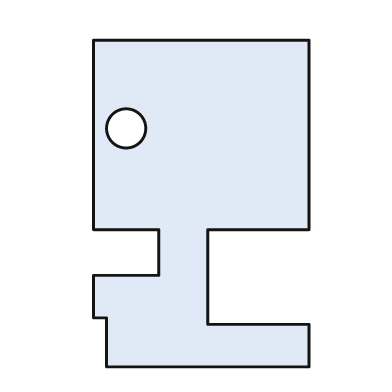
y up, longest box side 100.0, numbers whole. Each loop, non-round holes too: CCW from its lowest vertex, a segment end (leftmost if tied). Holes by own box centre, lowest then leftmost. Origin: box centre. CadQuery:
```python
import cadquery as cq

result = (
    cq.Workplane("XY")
    .moveTo(-29.0, -50.0)
    .lineTo(33.0, -50.0)
    .lineTo(33.0, -37.0)
    .lineTo(2.0, -37.0)
    .lineTo(2.0, -8.0)
    .lineTo(33.0, -8.0)
    .lineTo(33.0, 50.0)
    .lineTo(-33.0, 50.0)
    .lineTo(-33.0, -8.0)
    .lineTo(-13.0, -8.0)
    .lineTo(-13.0, -22.0)
    .lineTo(-33.0, -22.0)
    .lineTo(-33.0, -35.0)
    .lineTo(-29.0, -35.0)
    .close()
    .moveTo(-23.0, 23.0)
    .circle(6.0)
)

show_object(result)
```